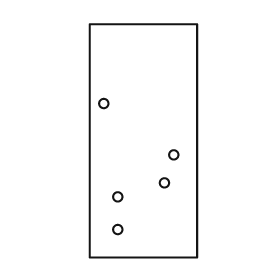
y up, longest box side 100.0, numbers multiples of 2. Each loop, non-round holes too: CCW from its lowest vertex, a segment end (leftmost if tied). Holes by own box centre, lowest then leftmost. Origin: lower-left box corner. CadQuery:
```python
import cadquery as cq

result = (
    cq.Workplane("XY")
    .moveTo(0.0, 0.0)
    .lineTo(46.0, 0.0)
    .lineTo(46.0, 100.0)
    .lineTo(0.0, 100.0)
    .close()
    .moveTo(12.0, 12.0)
    .circle(2.0)
    .moveTo(12.0, 26.0)
    .circle(2.0)
    .moveTo(32.0, 32.0)
    .circle(2.0)
    .moveTo(36.0, 44.0)
    .circle(2.0)
    .moveTo(6.0, 66.0)
    .circle(2.0)
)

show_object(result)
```